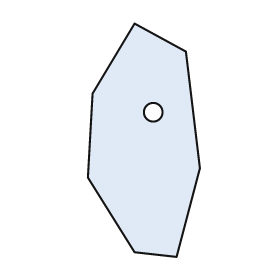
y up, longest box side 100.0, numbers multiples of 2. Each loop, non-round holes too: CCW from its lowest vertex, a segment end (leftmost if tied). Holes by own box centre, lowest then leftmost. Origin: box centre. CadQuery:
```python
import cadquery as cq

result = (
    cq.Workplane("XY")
    .moveTo(14.0, -50.0)
    .lineTo(24.0, -12.0)
    .lineTo(18.0, 38.0)
    .lineTo(-4.0, 50.0)
    .lineTo(-22.0, 20.0)
    .lineTo(-24.0, -16.0)
    .lineTo(-4.0, -48.0)
    .close()
    .moveTo(4.0, 12.0)
    .circle(4.0)
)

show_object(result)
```